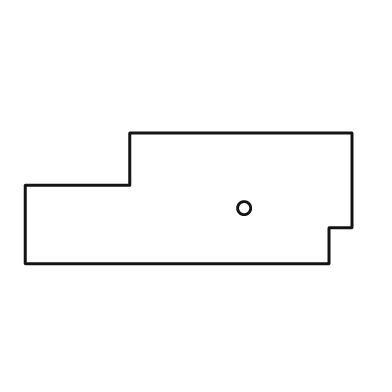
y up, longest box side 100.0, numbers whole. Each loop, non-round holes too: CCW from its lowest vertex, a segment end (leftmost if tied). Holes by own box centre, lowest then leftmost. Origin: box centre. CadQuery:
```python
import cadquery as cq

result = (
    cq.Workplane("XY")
    .moveTo(-50.0, -20.0)
    .lineTo(43.0, -20.0)
    .lineTo(43.0, -9.0)
    .lineTo(50.0, -9.0)
    .lineTo(50.0, 20.0)
    .lineTo(-18.0, 20.0)
    .lineTo(-18.0, 4.0)
    .lineTo(-50.0, 4.0)
    .close()
    .moveTo(17.0, -3.0)
    .circle(2.0)
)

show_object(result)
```